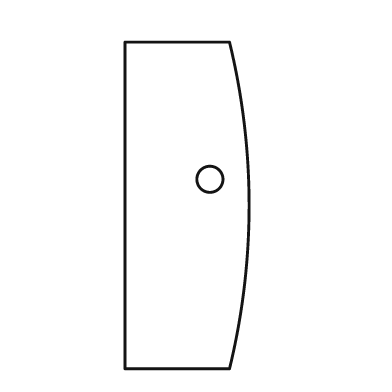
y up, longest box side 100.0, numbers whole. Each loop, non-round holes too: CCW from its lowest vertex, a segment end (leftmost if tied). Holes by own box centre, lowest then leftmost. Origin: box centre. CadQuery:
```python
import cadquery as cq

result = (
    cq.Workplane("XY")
    .moveTo(-19.0, -50.0)
    .lineTo(13.0, -50.0)
    .threePointArc((19.0, 0.0), (13.0, 50.0))
    .lineTo(-19.0, 50.0)
    .close()
    .moveTo(7.0, 8.0)
    .circle(4.0)
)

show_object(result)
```